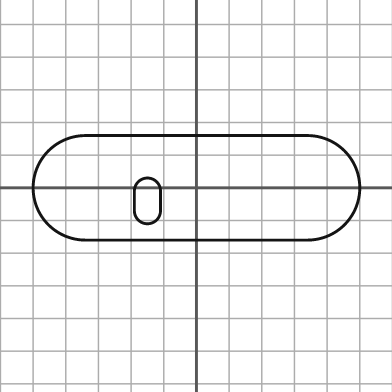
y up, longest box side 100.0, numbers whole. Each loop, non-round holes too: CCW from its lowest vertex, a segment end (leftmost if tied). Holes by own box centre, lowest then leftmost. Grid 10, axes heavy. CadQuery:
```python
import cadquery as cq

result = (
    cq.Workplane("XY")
    .moveTo(-34.0, -16.0)
    .lineTo(34.0, -16.0)
    .threePointArc((50.0, 0.0), (34.0, 16.0))
    .lineTo(-34.0, 16.0)
    .threePointArc((-50.0, 0.0), (-34.0, -16.0))
    .close()
    .moveTo(-19.0, -7.0)
    .threePointArc((-15.0, -11.0), (-11.0, -7.0))
    .lineTo(-11.0, -1.0)
    .threePointArc((-15.0, 3.0), (-19.0, -1.0))
    .close()
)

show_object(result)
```